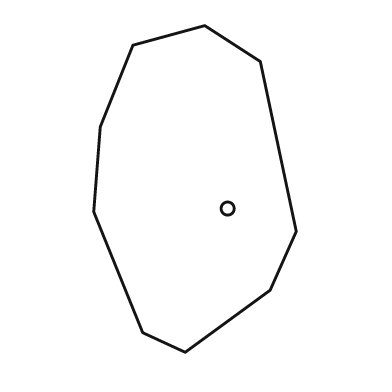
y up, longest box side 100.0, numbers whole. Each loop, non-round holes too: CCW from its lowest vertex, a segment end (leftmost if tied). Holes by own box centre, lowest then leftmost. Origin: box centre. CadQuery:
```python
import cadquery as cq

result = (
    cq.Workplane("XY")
    .moveTo(-3.0, -50.0)
    .lineTo(23.0, -31.0)
    .lineTo(31.0, -13.0)
    .lineTo(20.0, 39.0)
    .lineTo(3.0, 50.0)
    .lineTo(-19.0, 44.0)
    .lineTo(-29.0, 19.0)
    .lineTo(-31.0, -7.0)
    .lineTo(-16.0, -44.0)
    .close()
    .moveTo(10.0, -6.0)
    .circle(2.0)
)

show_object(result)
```